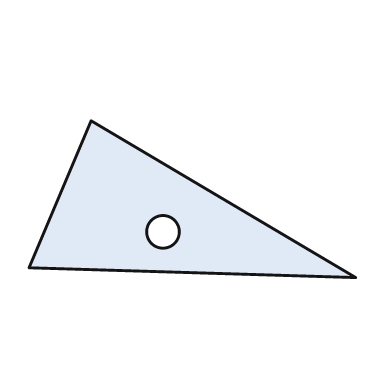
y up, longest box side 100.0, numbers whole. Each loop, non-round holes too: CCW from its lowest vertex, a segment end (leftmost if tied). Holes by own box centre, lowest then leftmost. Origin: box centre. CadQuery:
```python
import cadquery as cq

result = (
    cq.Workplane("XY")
    .moveTo(50.0, -24.0)
    .lineTo(-31.0, 24.0)
    .lineTo(-50.0, -21.0)
    .close()
    .moveTo(-9.0, -10.0)
    .circle(5.0)
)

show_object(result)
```